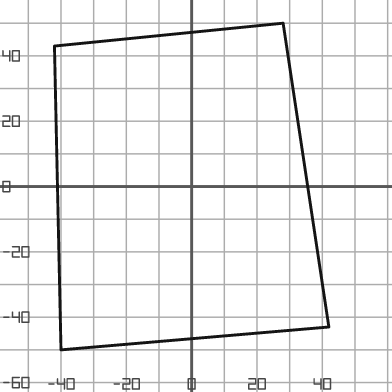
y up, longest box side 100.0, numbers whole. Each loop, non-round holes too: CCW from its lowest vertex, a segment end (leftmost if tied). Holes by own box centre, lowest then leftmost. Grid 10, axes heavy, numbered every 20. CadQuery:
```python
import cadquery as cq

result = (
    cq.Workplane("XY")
    .moveTo(-40.0, -50.0)
    .lineTo(42.0, -43.0)
    .lineTo(28.0, 50.0)
    .lineTo(-42.0, 43.0)
    .close()
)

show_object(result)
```